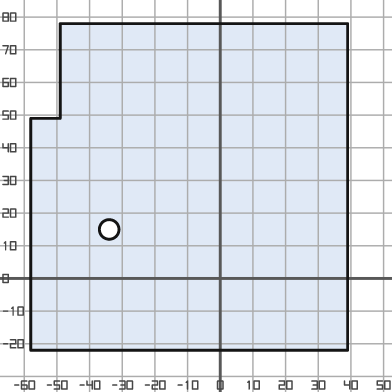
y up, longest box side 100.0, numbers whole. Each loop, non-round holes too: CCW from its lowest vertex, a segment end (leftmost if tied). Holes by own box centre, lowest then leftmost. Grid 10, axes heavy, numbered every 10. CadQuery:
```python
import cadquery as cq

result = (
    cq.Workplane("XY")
    .moveTo(-58.0, -22.0)
    .lineTo(39.0, -22.0)
    .lineTo(39.0, 78.0)
    .lineTo(-49.0, 78.0)
    .lineTo(-49.0, 49.0)
    .lineTo(-58.0, 49.0)
    .close()
    .moveTo(-34.0, 15.0)
    .circle(3.0)
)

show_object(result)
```